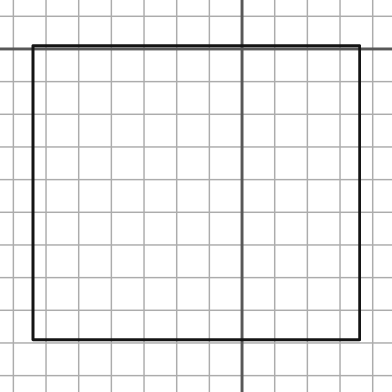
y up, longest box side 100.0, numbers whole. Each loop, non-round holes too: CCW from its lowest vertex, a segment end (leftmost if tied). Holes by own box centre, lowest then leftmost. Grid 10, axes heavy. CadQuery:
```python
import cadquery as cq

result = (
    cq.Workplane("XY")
    .moveTo(-64.0, -89.0)
    .lineTo(36.0, -89.0)
    .lineTo(36.0, 1.0)
    .lineTo(-64.0, 1.0)
    .close()
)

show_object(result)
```